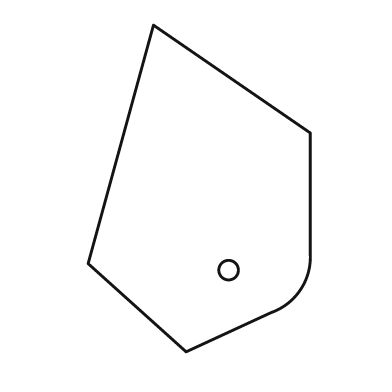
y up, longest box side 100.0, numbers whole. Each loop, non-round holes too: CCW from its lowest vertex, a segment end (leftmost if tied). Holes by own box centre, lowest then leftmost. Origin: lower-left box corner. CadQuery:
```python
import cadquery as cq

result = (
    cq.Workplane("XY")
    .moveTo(30.0, 0.0)
    .lineTo(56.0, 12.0)
    .threePointArc((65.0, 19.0), (68.0, 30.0))
    .lineTo(68.0, 67.0)
    .lineTo(20.0, 100.0)
    .lineTo(0.0, 27.0)
    .close()
    .moveTo(43.0, 25.0)
    .circle(3.0)
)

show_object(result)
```